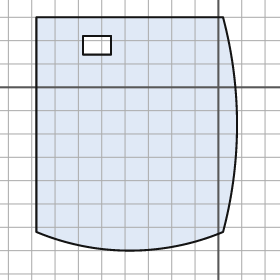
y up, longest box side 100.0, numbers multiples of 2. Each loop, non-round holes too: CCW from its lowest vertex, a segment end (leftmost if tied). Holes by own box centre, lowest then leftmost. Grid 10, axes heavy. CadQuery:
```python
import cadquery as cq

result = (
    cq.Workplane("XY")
    .moveTo(-78.0, -62.0)
    .threePointArc((-38.0, -70.0), (2.0, -62.0))
    .threePointArc((8.0, -16.0), (2.0, 30.0))
    .lineTo(-78.0, 30.0)
    .close()
    .moveTo(-58.0, 14.0)
    .lineTo(-46.0, 14.0)
    .lineTo(-46.0, 22.0)
    .lineTo(-58.0, 22.0)
    .close()
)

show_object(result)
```